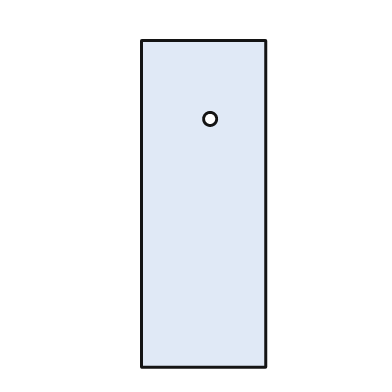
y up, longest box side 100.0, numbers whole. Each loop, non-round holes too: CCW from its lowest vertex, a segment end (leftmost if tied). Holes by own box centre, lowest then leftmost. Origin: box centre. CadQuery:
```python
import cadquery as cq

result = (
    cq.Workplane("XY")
    .moveTo(-19.0, -50.0)
    .lineTo(19.0, -50.0)
    .lineTo(19.0, 50.0)
    .lineTo(-19.0, 50.0)
    .close()
    .moveTo(2.0, 26.0)
    .circle(2.0)
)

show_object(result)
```